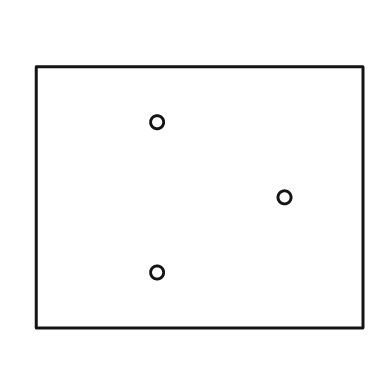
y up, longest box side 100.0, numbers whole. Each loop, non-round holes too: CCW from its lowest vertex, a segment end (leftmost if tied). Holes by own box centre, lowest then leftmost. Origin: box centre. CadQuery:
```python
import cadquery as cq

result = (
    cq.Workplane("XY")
    .moveTo(-50.0, -40.0)
    .lineTo(50.0, -40.0)
    .lineTo(50.0, 40.0)
    .lineTo(-50.0, 40.0)
    .close()
    .moveTo(-13.0, -23.0)
    .circle(2.0)
    .moveTo(26.0, 0.0)
    .circle(2.0)
    .moveTo(-13.0, 23.0)
    .circle(2.0)
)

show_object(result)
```